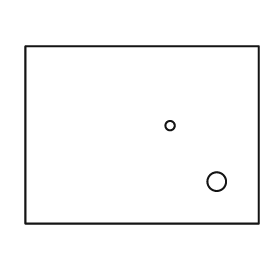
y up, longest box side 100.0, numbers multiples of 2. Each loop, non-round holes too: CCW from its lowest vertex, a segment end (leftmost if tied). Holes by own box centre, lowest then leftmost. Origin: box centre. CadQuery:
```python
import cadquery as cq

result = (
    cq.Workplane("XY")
    .moveTo(-50.0, -38.0)
    .lineTo(50.0, -38.0)
    .lineTo(50.0, 38.0)
    .lineTo(-50.0, 38.0)
    .close()
    .moveTo(32.0, -20.0)
    .circle(4.0)
    .moveTo(12.0, 4.0)
    .circle(2.0)
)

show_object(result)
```